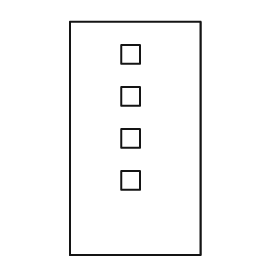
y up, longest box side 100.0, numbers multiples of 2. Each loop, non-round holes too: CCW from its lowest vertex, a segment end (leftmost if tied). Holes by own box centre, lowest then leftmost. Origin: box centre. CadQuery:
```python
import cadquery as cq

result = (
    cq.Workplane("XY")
    .moveTo(-28.0, -50.0)
    .lineTo(28.0, -50.0)
    .lineTo(28.0, 50.0)
    .lineTo(-28.0, 50.0)
    .close()
    .moveTo(-6.0, -22.0)
    .lineTo(2.0, -22.0)
    .lineTo(2.0, -14.0)
    .lineTo(-6.0, -14.0)
    .close()
    .moveTo(-6.0, -4.0)
    .lineTo(2.0, -4.0)
    .lineTo(2.0, 4.0)
    .lineTo(-6.0, 4.0)
    .close()
    .moveTo(-6.0, 14.0)
    .lineTo(2.0, 14.0)
    .lineTo(2.0, 22.0)
    .lineTo(-6.0, 22.0)
    .close()
    .moveTo(-6.0, 32.0)
    .lineTo(2.0, 32.0)
    .lineTo(2.0, 40.0)
    .lineTo(-6.0, 40.0)
    .close()
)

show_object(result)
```